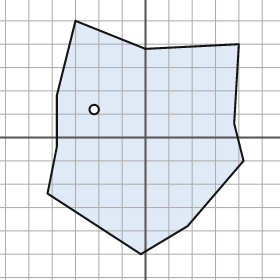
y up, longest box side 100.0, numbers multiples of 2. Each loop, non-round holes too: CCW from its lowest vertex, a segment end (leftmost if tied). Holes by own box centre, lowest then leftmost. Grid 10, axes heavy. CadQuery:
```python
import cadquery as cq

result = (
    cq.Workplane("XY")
    .moveTo(-2.0, -50.0)
    .lineTo(18.0, -38.0)
    .lineTo(42.0, -10.0)
    .lineTo(38.0, 6.0)
    .lineTo(40.0, 40.0)
    .lineTo(0.0, 38.0)
    .lineTo(-30.0, 50.0)
    .lineTo(-38.0, 18.0)
    .lineTo(-38.0, -4.0)
    .lineTo(-42.0, -24.0)
    .close()
    .moveTo(-22.0, 12.0)
    .circle(2.0)
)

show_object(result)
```